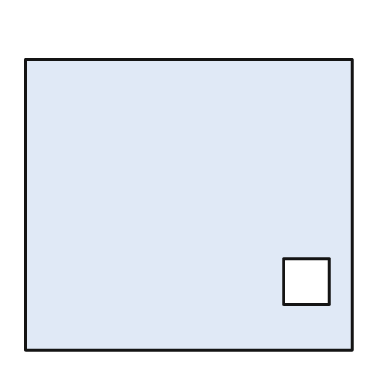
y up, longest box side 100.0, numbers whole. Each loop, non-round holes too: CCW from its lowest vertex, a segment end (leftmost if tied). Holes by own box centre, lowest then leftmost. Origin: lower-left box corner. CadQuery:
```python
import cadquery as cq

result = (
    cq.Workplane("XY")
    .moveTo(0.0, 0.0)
    .lineTo(100.0, 0.0)
    .lineTo(100.0, 89.0)
    .lineTo(0.0, 89.0)
    .close()
    .moveTo(79.0, 14.0)
    .lineTo(93.0, 14.0)
    .lineTo(93.0, 28.0)
    .lineTo(79.0, 28.0)
    .close()
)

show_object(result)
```